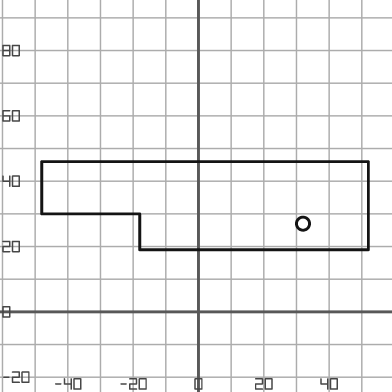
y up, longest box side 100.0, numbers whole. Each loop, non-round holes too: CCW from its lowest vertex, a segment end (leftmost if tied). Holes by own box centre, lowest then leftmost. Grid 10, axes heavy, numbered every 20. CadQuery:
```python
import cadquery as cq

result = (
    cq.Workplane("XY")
    .moveTo(-18.0, 19.0)
    .lineTo(52.0, 19.0)
    .lineTo(52.0, 46.0)
    .lineTo(-48.0, 46.0)
    .lineTo(-48.0, 30.0)
    .lineTo(-18.0, 30.0)
    .close()
    .moveTo(32.0, 27.0)
    .circle(2.0)
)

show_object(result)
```